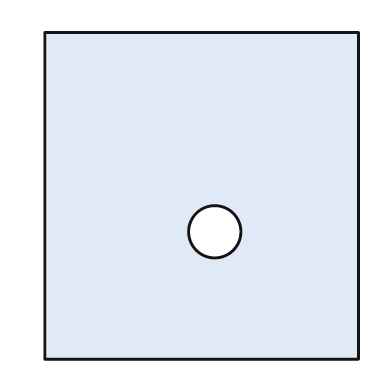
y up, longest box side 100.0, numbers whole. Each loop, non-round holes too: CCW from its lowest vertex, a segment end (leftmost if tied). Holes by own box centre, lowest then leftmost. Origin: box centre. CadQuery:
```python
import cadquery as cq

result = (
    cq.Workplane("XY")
    .moveTo(-48.0, -50.0)
    .lineTo(48.0, -50.0)
    .lineTo(48.0, 50.0)
    .lineTo(-48.0, 50.0)
    .close()
    .moveTo(4.0, -11.0)
    .circle(8.0)
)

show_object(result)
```